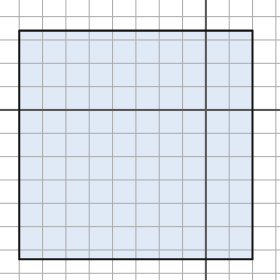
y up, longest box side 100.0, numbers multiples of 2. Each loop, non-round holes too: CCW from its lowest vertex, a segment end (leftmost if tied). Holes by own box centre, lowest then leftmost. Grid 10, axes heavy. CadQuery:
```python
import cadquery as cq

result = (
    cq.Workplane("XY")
    .moveTo(-80.0, -64.0)
    .lineTo(20.0, -64.0)
    .lineTo(20.0, 34.0)
    .lineTo(-80.0, 34.0)
    .close()
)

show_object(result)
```